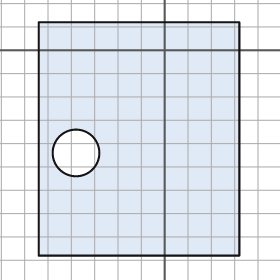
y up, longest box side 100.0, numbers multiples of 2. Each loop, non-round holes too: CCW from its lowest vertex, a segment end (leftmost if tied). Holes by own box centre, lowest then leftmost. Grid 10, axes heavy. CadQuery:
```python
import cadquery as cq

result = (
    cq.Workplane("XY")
    .moveTo(-54.0, -88.0)
    .lineTo(32.0, -88.0)
    .lineTo(32.0, 12.0)
    .lineTo(-54.0, 12.0)
    .close()
    .moveTo(-38.0, -44.0)
    .circle(10.0)
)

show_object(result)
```